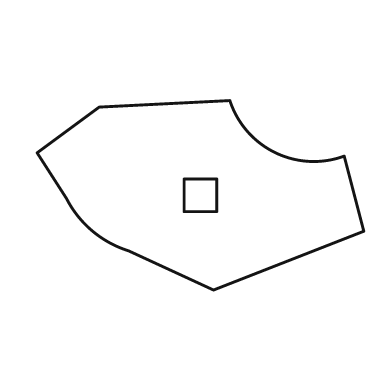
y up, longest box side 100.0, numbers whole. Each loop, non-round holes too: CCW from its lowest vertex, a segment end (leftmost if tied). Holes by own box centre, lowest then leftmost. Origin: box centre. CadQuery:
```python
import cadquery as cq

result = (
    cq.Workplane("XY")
    .moveTo(4.0, -29.0)
    .lineTo(50.0, -11.0)
    .lineTo(44.0, 12.0)
    .threePointArc((23.0, 13.0), (9.0, 29.0))
    .lineTo(-31.0, 27.0)
    .lineTo(-50.0, 13.0)
    .lineTo(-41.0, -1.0)
    .threePointArc((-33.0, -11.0), (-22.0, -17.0))
    .close()
    .moveTo(-5.0, -5.0)
    .lineTo(5.0, -5.0)
    .lineTo(5.0, 5.0)
    .lineTo(-5.0, 5.0)
    .close()
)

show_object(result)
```